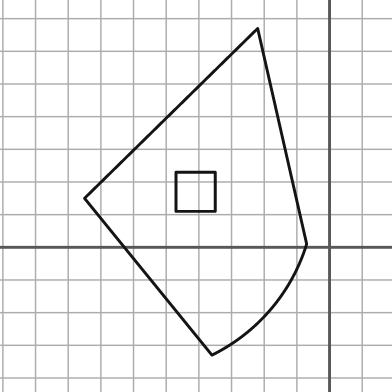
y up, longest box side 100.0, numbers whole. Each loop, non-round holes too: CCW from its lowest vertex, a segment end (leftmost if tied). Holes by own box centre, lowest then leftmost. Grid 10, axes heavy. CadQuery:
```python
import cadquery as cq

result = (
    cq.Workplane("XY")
    .moveTo(-36.0, -33.0)
    .threePointArc((-18.0, -19.0), (-7.0, 1.0))
    .lineTo(-22.0, 67.0)
    .lineTo(-75.0, 15.0)
    .close()
    .moveTo(-47.0, 11.0)
    .lineTo(-35.0, 11.0)
    .lineTo(-35.0, 23.0)
    .lineTo(-47.0, 23.0)
    .close()
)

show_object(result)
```